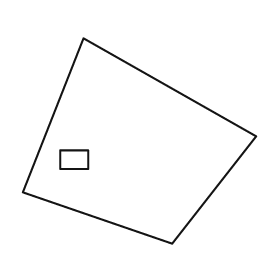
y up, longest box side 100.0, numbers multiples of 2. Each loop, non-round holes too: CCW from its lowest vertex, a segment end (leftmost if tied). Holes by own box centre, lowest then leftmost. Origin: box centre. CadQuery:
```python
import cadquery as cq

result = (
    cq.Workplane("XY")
    .moveTo(14.0, -44.0)
    .lineTo(50.0, 2.0)
    .lineTo(-24.0, 44.0)
    .lineTo(-50.0, -22.0)
    .close()
    .moveTo(-34.0, -12.0)
    .lineTo(-22.0, -12.0)
    .lineTo(-22.0, -4.0)
    .lineTo(-34.0, -4.0)
    .close()
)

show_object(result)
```